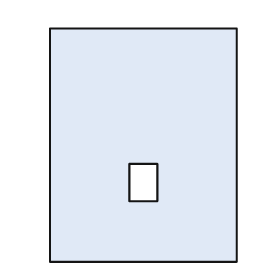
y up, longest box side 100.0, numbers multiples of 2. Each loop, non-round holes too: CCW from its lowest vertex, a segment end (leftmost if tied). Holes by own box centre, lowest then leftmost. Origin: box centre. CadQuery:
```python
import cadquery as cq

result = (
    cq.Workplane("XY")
    .moveTo(-40.0, -50.0)
    .lineTo(40.0, -50.0)
    .lineTo(40.0, 50.0)
    .lineTo(-40.0, 50.0)
    .close()
    .moveTo(-6.0, -24.0)
    .lineTo(6.0, -24.0)
    .lineTo(6.0, -8.0)
    .lineTo(-6.0, -8.0)
    .close()
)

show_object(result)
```